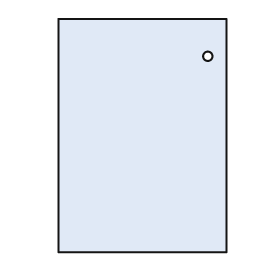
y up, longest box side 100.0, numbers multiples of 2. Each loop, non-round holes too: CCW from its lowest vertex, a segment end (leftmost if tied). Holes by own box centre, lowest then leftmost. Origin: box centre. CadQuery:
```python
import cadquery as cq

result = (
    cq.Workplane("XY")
    .moveTo(-36.0, -50.0)
    .lineTo(36.0, -50.0)
    .lineTo(36.0, 50.0)
    .lineTo(-36.0, 50.0)
    .close()
    .moveTo(28.0, 34.0)
    .circle(2.0)
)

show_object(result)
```